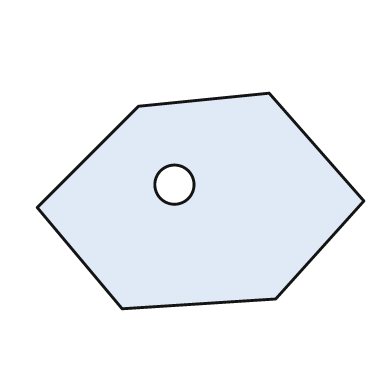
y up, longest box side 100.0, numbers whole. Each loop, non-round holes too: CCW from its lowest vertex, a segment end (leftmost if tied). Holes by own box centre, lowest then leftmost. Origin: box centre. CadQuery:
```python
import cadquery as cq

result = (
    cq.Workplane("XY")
    .moveTo(-24.0, -33.0)
    .lineTo(23.0, -30.0)
    .lineTo(50.0, 0.0)
    .lineTo(21.0, 33.0)
    .lineTo(-19.0, 29.0)
    .lineTo(-50.0, -2.0)
    .close()
    .moveTo(-8.0, 5.0)
    .circle(6.0)
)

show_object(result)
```